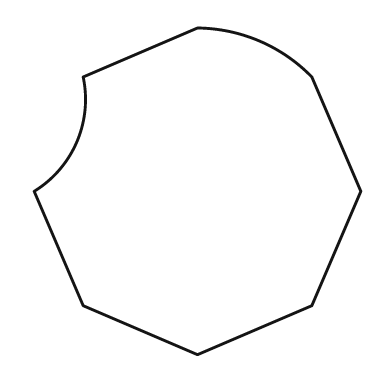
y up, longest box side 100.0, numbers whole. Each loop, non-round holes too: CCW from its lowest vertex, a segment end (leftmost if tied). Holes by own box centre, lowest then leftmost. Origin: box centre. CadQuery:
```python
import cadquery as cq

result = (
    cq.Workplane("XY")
    .moveTo(0.0, -50.0)
    .lineTo(35.0, -35.0)
    .lineTo(50.0, 0.0)
    .lineTo(35.0, 35.0)
    .threePointArc((19.0, 46.0), (0.0, 50.0))
    .lineTo(-35.0, 35.0)
    .threePointArc((-37.0, 15.0), (-50.0, 0.0))
    .lineTo(-35.0, -35.0)
    .close()
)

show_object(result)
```